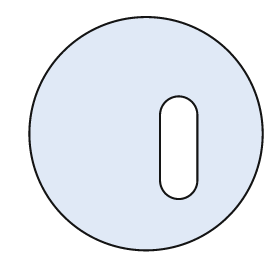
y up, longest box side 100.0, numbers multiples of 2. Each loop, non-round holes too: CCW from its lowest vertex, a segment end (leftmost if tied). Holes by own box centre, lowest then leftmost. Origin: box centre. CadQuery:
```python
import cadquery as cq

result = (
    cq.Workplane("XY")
    .moveTo(0.0, 0.0)
    .circle(50.0)
    .moveTo(6.0, -20.0)
    .threePointArc((14.0, -28.0), (22.0, -20.0))
    .lineTo(22.0, 8.0)
    .threePointArc((14.0, 16.0), (6.0, 8.0))
    .close()
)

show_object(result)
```